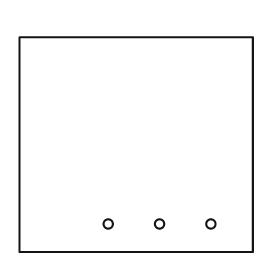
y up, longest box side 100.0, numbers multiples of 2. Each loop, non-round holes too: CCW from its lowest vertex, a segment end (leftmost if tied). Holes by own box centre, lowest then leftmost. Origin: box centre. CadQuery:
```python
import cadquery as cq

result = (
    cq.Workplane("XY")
    .moveTo(-50.0, -46.0)
    .lineTo(50.0, -46.0)
    .lineTo(50.0, 46.0)
    .lineTo(-50.0, 46.0)
    .close()
    .moveTo(-12.0, -34.0)
    .circle(2.0)
    .moveTo(10.0, -34.0)
    .circle(2.0)
    .moveTo(32.0, -34.0)
    .circle(2.0)
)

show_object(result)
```